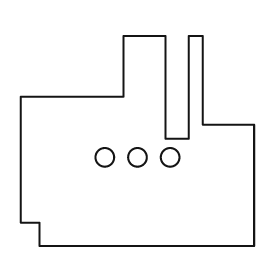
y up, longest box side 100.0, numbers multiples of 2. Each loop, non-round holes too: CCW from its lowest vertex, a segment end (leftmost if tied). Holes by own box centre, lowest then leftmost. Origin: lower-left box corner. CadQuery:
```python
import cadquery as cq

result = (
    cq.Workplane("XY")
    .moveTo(8.0, 0.0)
    .lineTo(100.0, 0.0)
    .lineTo(100.0, 52.0)
    .lineTo(78.0, 52.0)
    .lineTo(78.0, 90.0)
    .lineTo(72.0, 90.0)
    .lineTo(72.0, 46.0)
    .lineTo(62.0, 46.0)
    .lineTo(62.0, 90.0)
    .lineTo(44.0, 90.0)
    .lineTo(44.0, 64.0)
    .lineTo(0.0, 64.0)
    .lineTo(0.0, 10.0)
    .lineTo(8.0, 10.0)
    .close()
    .moveTo(36.0, 38.0)
    .circle(4.0)
    .moveTo(50.0, 38.0)
    .circle(4.0)
    .moveTo(64.0, 38.0)
    .circle(4.0)
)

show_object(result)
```